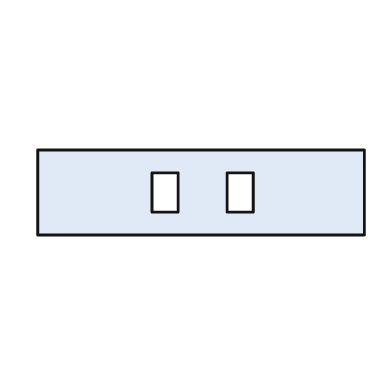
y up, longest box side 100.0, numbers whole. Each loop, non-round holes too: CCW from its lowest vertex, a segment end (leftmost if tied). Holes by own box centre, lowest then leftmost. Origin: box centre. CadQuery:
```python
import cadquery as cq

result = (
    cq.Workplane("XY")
    .moveTo(-50.0, -13.0)
    .lineTo(50.0, -13.0)
    .lineTo(50.0, 13.0)
    .lineTo(-50.0, 13.0)
    .close()
    .moveTo(-15.0, -6.0)
    .lineTo(-7.0, -6.0)
    .lineTo(-7.0, 6.0)
    .lineTo(-15.0, 6.0)
    .close()
    .moveTo(8.0, -6.0)
    .lineTo(16.0, -6.0)
    .lineTo(16.0, 6.0)
    .lineTo(8.0, 6.0)
    .close()
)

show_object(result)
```